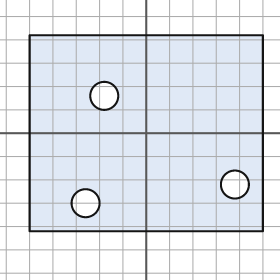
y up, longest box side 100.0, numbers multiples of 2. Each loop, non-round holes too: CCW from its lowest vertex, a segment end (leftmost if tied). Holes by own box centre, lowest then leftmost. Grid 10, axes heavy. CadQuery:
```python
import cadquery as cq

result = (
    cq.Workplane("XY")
    .moveTo(-50.0, -42.0)
    .lineTo(50.0, -42.0)
    .lineTo(50.0, 42.0)
    .lineTo(-50.0, 42.0)
    .close()
    .moveTo(-26.0, -30.0)
    .circle(6.0)
    .moveTo(38.0, -22.0)
    .circle(6.0)
    .moveTo(-18.0, 16.0)
    .circle(6.0)
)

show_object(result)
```